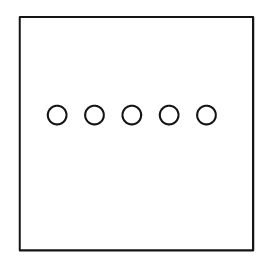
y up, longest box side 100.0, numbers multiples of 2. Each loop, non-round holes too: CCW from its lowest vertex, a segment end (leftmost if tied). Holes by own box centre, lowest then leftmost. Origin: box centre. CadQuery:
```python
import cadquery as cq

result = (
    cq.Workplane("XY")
    .moveTo(-50.0, -50.0)
    .lineTo(50.0, -50.0)
    .lineTo(50.0, 50.0)
    .lineTo(-50.0, 50.0)
    .close()
    .moveTo(-34.0, 8.0)
    .circle(4.0)
    .moveTo(-18.0, 8.0)
    .circle(4.0)
    .moveTo(-2.0, 8.0)
    .circle(4.0)
    .moveTo(14.0, 8.0)
    .circle(4.0)
    .moveTo(30.0, 8.0)
    .circle(4.0)
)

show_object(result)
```